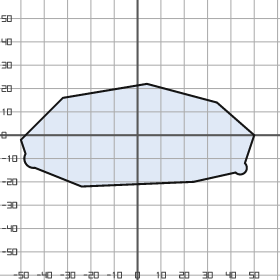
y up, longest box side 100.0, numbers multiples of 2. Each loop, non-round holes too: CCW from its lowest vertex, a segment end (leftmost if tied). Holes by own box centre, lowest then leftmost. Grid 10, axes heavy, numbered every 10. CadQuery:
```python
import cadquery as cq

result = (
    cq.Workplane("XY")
    .moveTo(-24.0, -22.0)
    .lineTo(24.0, -20.0)
    .lineTo(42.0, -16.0)
    .threePointArc((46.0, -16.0), (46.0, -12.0))
    .lineTo(50.0, 0.0)
    .lineTo(34.0, 14.0)
    .lineTo(4.0, 22.0)
    .lineTo(-32.0, 16.0)
    .lineTo(-50.0, -2.0)
    .lineTo(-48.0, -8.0)
    .threePointArc((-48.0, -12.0), (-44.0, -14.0))
    .close()
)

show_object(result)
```